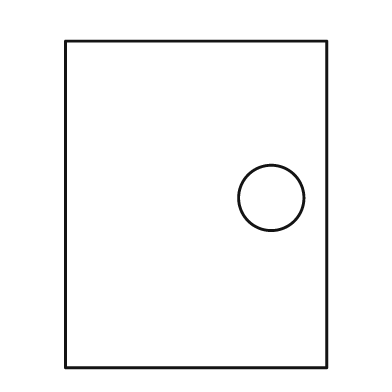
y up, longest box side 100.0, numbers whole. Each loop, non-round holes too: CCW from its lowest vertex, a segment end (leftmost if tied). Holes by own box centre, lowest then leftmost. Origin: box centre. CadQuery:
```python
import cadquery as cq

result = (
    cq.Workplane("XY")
    .moveTo(-40.0, -50.0)
    .lineTo(40.0, -50.0)
    .lineTo(40.0, 50.0)
    .lineTo(-40.0, 50.0)
    .close()
    .moveTo(23.0, 2.0)
    .circle(10.0)
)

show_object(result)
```